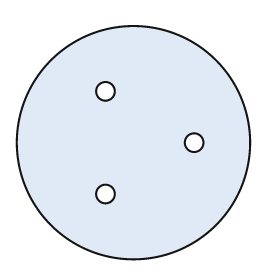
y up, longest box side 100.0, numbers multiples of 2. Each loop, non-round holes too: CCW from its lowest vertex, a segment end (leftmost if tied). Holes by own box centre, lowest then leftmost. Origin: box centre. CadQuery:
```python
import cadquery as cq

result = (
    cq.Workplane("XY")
    .moveTo(0.0, 0.0)
    .circle(50.0)
    .moveTo(-12.0, -22.0)
    .circle(4.0)
    .moveTo(26.0, 0.0)
    .circle(4.0)
    .moveTo(-12.0, 22.0)
    .circle(4.0)
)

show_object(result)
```